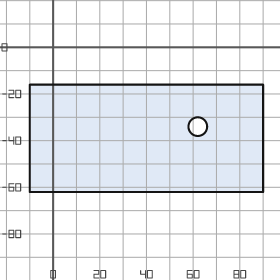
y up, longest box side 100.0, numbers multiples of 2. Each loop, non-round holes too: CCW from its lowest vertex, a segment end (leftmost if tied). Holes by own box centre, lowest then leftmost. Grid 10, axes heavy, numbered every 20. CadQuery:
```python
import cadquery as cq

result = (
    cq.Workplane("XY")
    .moveTo(-10.0, -62.0)
    .lineTo(90.0, -62.0)
    .lineTo(90.0, -16.0)
    .lineTo(-10.0, -16.0)
    .close()
    .moveTo(62.0, -34.0)
    .circle(4.0)
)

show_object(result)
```